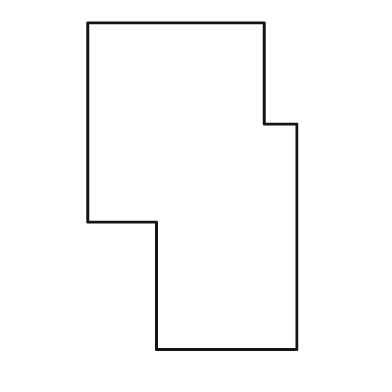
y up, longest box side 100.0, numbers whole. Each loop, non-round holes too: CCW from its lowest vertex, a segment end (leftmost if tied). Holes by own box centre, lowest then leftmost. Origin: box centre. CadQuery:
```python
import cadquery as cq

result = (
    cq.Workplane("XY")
    .moveTo(-11.0, -50.0)
    .lineTo(32.0, -50.0)
    .lineTo(32.0, 19.0)
    .lineTo(22.0, 19.0)
    .lineTo(22.0, 50.0)
    .lineTo(-32.0, 50.0)
    .lineTo(-32.0, -11.0)
    .lineTo(-11.0, -11.0)
    .close()
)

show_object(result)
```